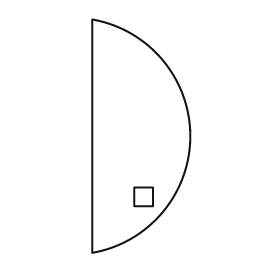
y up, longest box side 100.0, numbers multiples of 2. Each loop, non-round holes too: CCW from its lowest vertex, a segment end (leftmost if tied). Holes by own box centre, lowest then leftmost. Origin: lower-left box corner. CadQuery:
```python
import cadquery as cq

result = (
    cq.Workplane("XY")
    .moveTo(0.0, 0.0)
    .threePointArc((42.0, 50.0), (0.0, 100.0))
    .close()
    .moveTo(18.0, 20.0)
    .lineTo(26.0, 20.0)
    .lineTo(26.0, 28.0)
    .lineTo(18.0, 28.0)
    .close()
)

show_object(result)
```